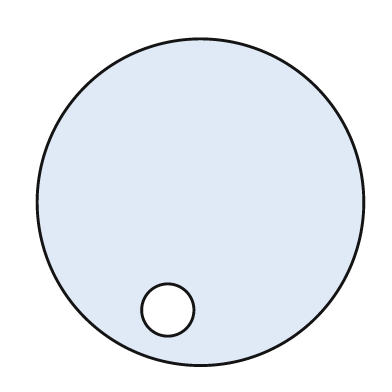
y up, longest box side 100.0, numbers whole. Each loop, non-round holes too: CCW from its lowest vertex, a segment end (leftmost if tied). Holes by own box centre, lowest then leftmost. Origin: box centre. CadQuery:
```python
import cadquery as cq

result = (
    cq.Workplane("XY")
    .moveTo(0.0, 0.0)
    .circle(50.0)
    .moveTo(-10.0, -33.0)
    .circle(8.0)
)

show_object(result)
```